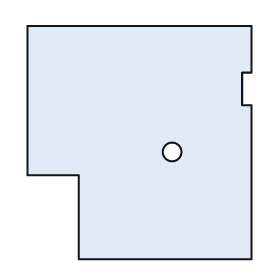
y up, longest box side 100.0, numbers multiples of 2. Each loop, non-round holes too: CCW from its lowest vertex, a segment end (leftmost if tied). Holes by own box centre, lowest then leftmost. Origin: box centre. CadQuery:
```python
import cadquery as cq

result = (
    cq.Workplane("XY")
    .moveTo(-26.0, -50.0)
    .lineTo(48.0, -50.0)
    .lineTo(48.0, 16.0)
    .lineTo(44.0, 16.0)
    .lineTo(44.0, 30.0)
    .lineTo(48.0, 30.0)
    .lineTo(48.0, 50.0)
    .lineTo(-48.0, 50.0)
    .lineTo(-48.0, -14.0)
    .lineTo(-26.0, -14.0)
    .close()
    .moveTo(14.0, -4.0)
    .circle(4.0)
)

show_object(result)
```